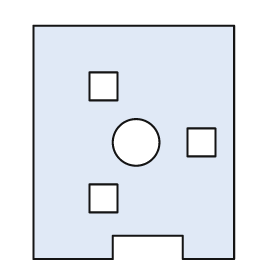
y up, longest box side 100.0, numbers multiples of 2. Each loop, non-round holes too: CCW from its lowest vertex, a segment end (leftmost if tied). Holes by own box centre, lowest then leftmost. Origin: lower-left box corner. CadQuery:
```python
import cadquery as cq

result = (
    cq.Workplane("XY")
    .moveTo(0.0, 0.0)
    .lineTo(34.0, 0.0)
    .lineTo(34.0, 10.0)
    .lineTo(64.0, 10.0)
    .lineTo(64.0, 0.0)
    .lineTo(86.0, 0.0)
    .lineTo(86.0, 100.0)
    .lineTo(0.0, 100.0)
    .close()
    .moveTo(24.0, 20.0)
    .lineTo(36.0, 20.0)
    .lineTo(36.0, 32.0)
    .lineTo(24.0, 32.0)
    .close()
    .moveTo(44.0, 50.0)
    .circle(10.0)
    .moveTo(66.0, 44.0)
    .lineTo(78.0, 44.0)
    .lineTo(78.0, 56.0)
    .lineTo(66.0, 56.0)
    .close()
    .moveTo(24.0, 68.0)
    .lineTo(36.0, 68.0)
    .lineTo(36.0, 80.0)
    .lineTo(24.0, 80.0)
    .close()
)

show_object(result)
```